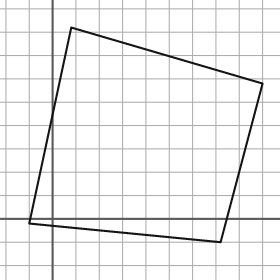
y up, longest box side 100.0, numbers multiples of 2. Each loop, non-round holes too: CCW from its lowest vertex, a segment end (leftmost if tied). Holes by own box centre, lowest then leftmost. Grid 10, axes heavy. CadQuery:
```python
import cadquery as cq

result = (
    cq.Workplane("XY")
    .moveTo(72.0, -10.0)
    .lineTo(90.0, 58.0)
    .lineTo(8.0, 82.0)
    .lineTo(-10.0, -2.0)
    .close()
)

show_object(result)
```